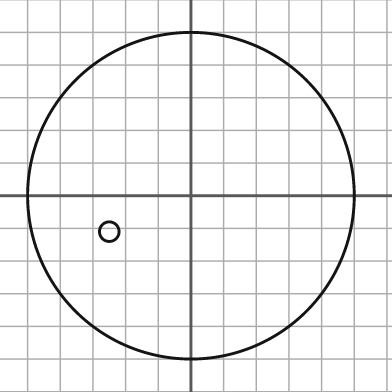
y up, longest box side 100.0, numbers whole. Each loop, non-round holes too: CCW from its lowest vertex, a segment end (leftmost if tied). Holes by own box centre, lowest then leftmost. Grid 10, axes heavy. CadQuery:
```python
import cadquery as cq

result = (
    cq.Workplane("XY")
    .moveTo(0.0, 0.0)
    .circle(50.0)
    .moveTo(-25.0, -11.0)
    .circle(3.0)
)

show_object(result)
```